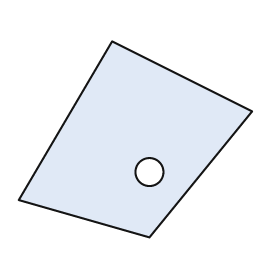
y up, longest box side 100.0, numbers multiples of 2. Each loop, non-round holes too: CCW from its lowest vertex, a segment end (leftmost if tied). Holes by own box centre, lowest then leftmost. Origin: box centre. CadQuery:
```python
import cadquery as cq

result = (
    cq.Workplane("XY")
    .moveTo(6.0, -42.0)
    .lineTo(50.0, 12.0)
    .lineTo(-10.0, 42.0)
    .lineTo(-50.0, -26.0)
    .close()
    .moveTo(6.0, -14.0)
    .circle(6.0)
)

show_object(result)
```